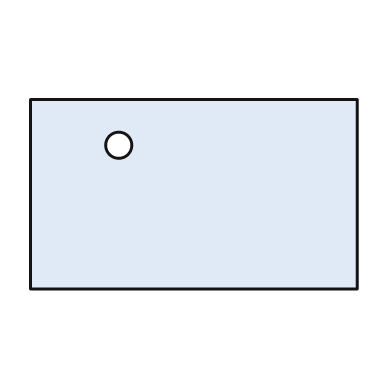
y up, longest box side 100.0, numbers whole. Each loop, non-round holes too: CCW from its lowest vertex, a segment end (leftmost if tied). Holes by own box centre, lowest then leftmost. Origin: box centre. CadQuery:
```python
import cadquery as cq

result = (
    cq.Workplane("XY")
    .moveTo(-50.0, -29.0)
    .lineTo(50.0, -29.0)
    .lineTo(50.0, 29.0)
    .lineTo(-50.0, 29.0)
    .close()
    .moveTo(-23.0, 15.0)
    .circle(4.0)
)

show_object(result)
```